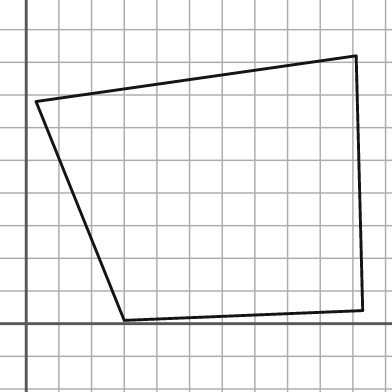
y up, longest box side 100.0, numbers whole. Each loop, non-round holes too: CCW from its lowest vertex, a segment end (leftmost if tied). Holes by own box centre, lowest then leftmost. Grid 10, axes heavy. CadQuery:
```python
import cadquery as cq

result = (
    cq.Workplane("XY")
    .moveTo(30.0, 1.0)
    .lineTo(103.0, 4.0)
    .lineTo(101.0, 82.0)
    .lineTo(3.0, 68.0)
    .close()
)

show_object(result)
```